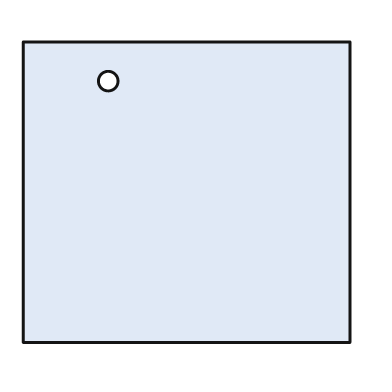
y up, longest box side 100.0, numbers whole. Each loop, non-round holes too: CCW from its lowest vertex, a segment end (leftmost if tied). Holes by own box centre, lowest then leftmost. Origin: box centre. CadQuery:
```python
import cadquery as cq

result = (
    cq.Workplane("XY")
    .moveTo(-50.0, -46.0)
    .lineTo(50.0, -46.0)
    .lineTo(50.0, 46.0)
    .lineTo(-50.0, 46.0)
    .close()
    .moveTo(-24.0, 34.0)
    .circle(3.0)
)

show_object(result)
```